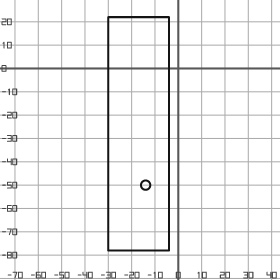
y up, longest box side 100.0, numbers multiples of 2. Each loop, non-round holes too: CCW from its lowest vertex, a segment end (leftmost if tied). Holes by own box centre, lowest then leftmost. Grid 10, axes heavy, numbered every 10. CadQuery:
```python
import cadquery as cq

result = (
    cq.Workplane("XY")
    .moveTo(-30.0, -78.0)
    .lineTo(-4.0, -78.0)
    .lineTo(-4.0, 22.0)
    .lineTo(-30.0, 22.0)
    .close()
    .moveTo(-14.0, -50.0)
    .circle(2.0)
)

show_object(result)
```